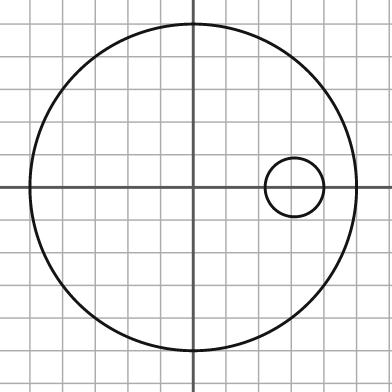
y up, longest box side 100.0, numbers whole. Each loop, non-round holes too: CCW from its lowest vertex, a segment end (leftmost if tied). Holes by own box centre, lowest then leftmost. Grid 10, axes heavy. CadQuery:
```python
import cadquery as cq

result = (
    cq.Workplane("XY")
    .moveTo(0.0, 0.0)
    .circle(50.0)
    .moveTo(31.0, 0.0)
    .circle(9.0)
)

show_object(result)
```